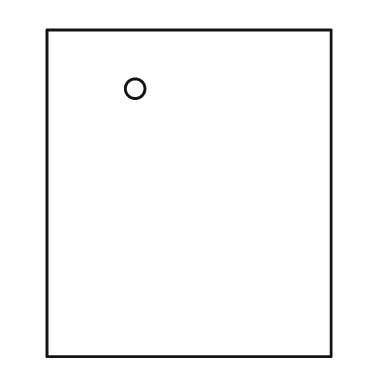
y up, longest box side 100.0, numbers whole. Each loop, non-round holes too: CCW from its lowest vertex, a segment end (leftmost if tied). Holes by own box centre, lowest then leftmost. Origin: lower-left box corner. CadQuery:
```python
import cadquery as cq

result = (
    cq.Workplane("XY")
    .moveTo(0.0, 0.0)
    .lineTo(87.0, 0.0)
    .lineTo(87.0, 100.0)
    .lineTo(0.0, 100.0)
    .close()
    .moveTo(27.0, 82.0)
    .circle(3.0)
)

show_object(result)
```